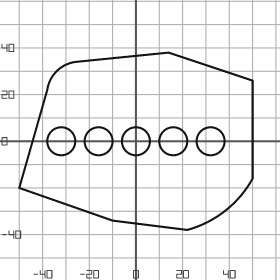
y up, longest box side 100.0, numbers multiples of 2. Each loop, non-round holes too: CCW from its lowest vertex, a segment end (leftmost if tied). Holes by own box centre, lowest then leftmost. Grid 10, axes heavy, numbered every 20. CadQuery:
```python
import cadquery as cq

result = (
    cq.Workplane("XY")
    .moveTo(22.0, -38.0)
    .threePointArc((38.0, -30.0), (50.0, -16.0))
    .lineTo(50.0, 26.0)
    .lineTo(14.0, 38.0)
    .lineTo(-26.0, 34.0)
    .threePointArc((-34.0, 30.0), (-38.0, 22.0))
    .lineTo(-50.0, -20.0)
    .lineTo(-10.0, -34.0)
    .close()
    .moveTo(-32.0, 0.0)
    .circle(6.0)
    .moveTo(-16.0, 0.0)
    .circle(6.0)
    .moveTo(0.0, 0.0)
    .circle(6.0)
    .moveTo(16.0, 0.0)
    .circle(6.0)
    .moveTo(32.0, 0.0)
    .circle(6.0)
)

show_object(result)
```